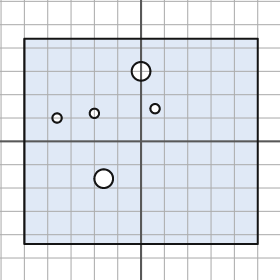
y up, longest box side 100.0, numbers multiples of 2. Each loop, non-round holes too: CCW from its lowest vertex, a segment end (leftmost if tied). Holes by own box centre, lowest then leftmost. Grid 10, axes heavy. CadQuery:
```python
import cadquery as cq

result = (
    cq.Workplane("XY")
    .moveTo(-50.0, -44.0)
    .lineTo(50.0, -44.0)
    .lineTo(50.0, 44.0)
    .lineTo(-50.0, 44.0)
    .close()
    .moveTo(-16.0, -16.0)
    .circle(4.0)
    .moveTo(-36.0, 10.0)
    .circle(2.0)
    .moveTo(-20.0, 12.0)
    .circle(2.0)
    .moveTo(6.0, 14.0)
    .circle(2.0)
    .moveTo(0.0, 30.0)
    .circle(4.0)
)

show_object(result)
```